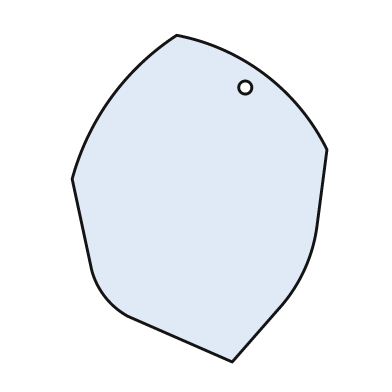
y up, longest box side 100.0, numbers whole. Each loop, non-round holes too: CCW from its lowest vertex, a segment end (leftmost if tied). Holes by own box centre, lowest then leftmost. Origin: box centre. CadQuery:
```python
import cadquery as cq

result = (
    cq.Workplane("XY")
    .moveTo(10.0, -50.0)
    .lineTo(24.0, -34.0)
    .threePointArc((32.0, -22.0), (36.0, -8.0))
    .lineTo(39.0, 15.0)
    .threePointArc((20.0, 38.0), (-7.0, 50.0))
    .threePointArc((-27.0, 31.0), (-39.0, 6.0))
    .lineTo(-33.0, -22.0)
    .threePointArc((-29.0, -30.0), (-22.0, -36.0))
    .close()
    .moveTo(14.0, 34.0)
    .circle(2.0)
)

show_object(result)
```